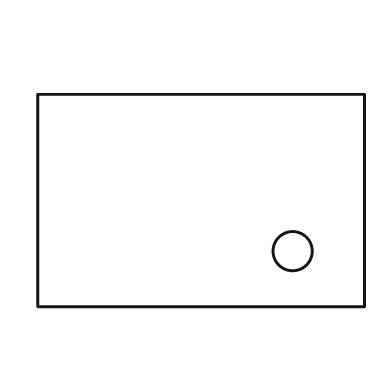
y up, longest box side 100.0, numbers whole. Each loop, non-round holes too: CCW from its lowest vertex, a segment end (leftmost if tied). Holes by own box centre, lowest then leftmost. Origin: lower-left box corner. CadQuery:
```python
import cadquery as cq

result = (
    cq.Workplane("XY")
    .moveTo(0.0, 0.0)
    .lineTo(100.0, 0.0)
    .lineTo(100.0, 65.0)
    .lineTo(0.0, 65.0)
    .close()
    .moveTo(78.0, 17.0)
    .circle(6.0)
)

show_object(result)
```